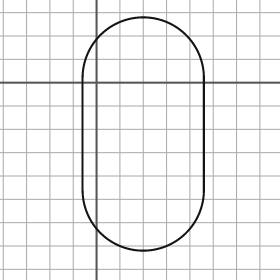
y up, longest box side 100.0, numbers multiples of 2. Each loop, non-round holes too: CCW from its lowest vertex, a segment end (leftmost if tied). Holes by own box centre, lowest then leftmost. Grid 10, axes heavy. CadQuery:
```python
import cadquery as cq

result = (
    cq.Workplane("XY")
    .moveTo(-6.0, -46.0)
    .threePointArc((20.0, -72.0), (46.0, -46.0))
    .lineTo(46.0, 2.0)
    .threePointArc((20.0, 28.0), (-6.0, 2.0))
    .close()
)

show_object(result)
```